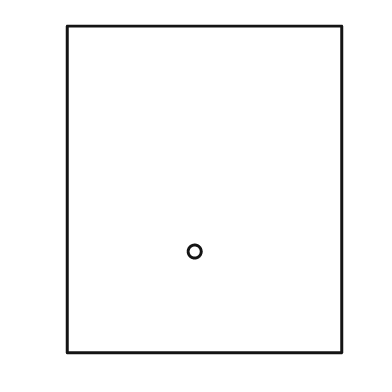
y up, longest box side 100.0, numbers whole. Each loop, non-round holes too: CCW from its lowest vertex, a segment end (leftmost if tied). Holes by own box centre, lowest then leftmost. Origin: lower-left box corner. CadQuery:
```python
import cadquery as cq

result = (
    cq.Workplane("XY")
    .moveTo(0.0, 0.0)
    .lineTo(84.0, 0.0)
    .lineTo(84.0, 100.0)
    .lineTo(0.0, 100.0)
    .close()
    .moveTo(39.0, 31.0)
    .circle(2.0)
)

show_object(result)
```